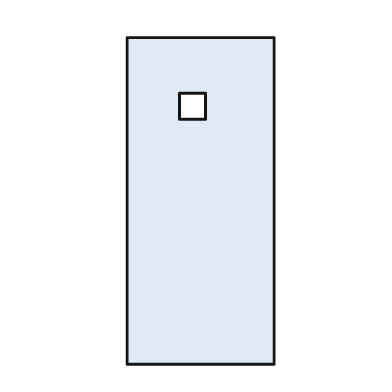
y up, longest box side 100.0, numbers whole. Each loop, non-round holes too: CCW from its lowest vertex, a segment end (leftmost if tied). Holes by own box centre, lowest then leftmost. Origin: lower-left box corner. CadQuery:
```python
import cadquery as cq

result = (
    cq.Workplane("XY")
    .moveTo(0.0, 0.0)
    .lineTo(45.0, 0.0)
    .lineTo(45.0, 100.0)
    .lineTo(0.0, 100.0)
    .close()
    .moveTo(16.0, 75.0)
    .lineTo(24.0, 75.0)
    .lineTo(24.0, 83.0)
    .lineTo(16.0, 83.0)
    .close()
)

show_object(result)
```